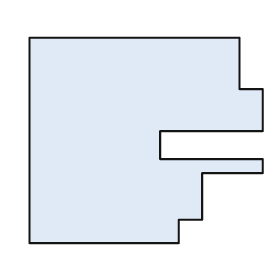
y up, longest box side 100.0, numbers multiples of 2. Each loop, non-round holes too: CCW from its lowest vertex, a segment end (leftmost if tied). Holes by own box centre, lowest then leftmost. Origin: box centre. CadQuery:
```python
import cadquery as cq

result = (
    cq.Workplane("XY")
    .moveTo(-50.0, -44.0)
    .lineTo(14.0, -44.0)
    .lineTo(14.0, -34.0)
    .lineTo(24.0, -34.0)
    .lineTo(24.0, -14.0)
    .lineTo(50.0, -14.0)
    .lineTo(50.0, -8.0)
    .lineTo(6.0, -8.0)
    .lineTo(6.0, 4.0)
    .lineTo(50.0, 4.0)
    .lineTo(50.0, 22.0)
    .lineTo(40.0, 22.0)
    .lineTo(40.0, 44.0)
    .lineTo(-50.0, 44.0)
    .close()
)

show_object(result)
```